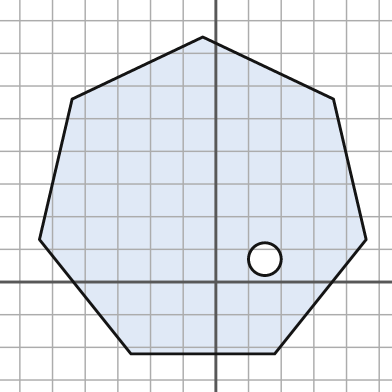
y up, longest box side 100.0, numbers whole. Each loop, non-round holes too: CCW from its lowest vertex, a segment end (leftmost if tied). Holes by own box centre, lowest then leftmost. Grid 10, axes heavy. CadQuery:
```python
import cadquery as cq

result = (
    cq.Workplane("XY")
    .moveTo(-26.0, -22.0)
    .lineTo(18.0, -22.0)
    .lineTo(46.0, 13.0)
    .lineTo(36.0, 56.0)
    .lineTo(-4.0, 75.0)
    .lineTo(-44.0, 56.0)
    .lineTo(-54.0, 13.0)
    .close()
    .moveTo(15.0, 7.0)
    .circle(5.0)
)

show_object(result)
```